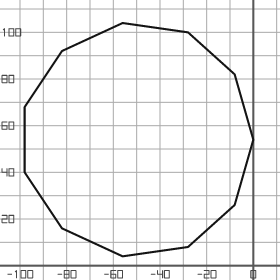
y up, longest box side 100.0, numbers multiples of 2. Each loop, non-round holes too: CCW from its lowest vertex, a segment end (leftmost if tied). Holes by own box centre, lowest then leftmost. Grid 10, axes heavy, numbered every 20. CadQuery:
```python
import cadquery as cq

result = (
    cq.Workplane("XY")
    .moveTo(-56.0, 4.0)
    .lineTo(-28.0, 8.0)
    .lineTo(-8.0, 26.0)
    .lineTo(0.0, 54.0)
    .lineTo(-8.0, 82.0)
    .lineTo(-28.0, 100.0)
    .lineTo(-56.0, 104.0)
    .lineTo(-82.0, 92.0)
    .lineTo(-98.0, 68.0)
    .lineTo(-98.0, 40.0)
    .lineTo(-82.0, 16.0)
    .close()
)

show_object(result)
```